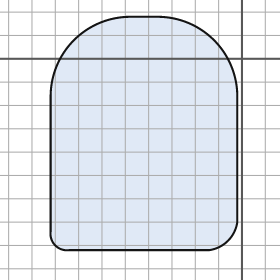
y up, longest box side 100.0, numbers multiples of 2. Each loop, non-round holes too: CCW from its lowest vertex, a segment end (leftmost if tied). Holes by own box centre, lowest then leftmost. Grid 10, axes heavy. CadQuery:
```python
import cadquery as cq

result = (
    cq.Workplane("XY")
    .moveTo(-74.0, -82.0)
    .lineTo(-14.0, -82.0)
    .threePointArc((-6.0, -78.0), (-2.0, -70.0))
    .lineTo(-2.0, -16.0)
    .threePointArc((-12.0, 8.0), (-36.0, 18.0))
    .lineTo(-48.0, 18.0)
    .threePointArc((-72.0, 8.0), (-82.0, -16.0))
    .lineTo(-82.0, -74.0)
    .threePointArc((-80.0, -80.0), (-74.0, -82.0))
    .close()
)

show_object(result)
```